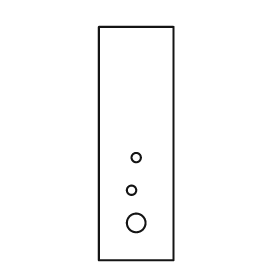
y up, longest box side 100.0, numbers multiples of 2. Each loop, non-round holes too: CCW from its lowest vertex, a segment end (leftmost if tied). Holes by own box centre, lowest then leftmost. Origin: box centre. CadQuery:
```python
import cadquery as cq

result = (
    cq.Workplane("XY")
    .moveTo(-16.0, -50.0)
    .lineTo(16.0, -50.0)
    .lineTo(16.0, 50.0)
    .lineTo(-16.0, 50.0)
    .close()
    .moveTo(0.0, -34.0)
    .circle(4.0)
    .moveTo(-2.0, -20.0)
    .circle(2.0)
    .moveTo(0.0, -6.0)
    .circle(2.0)
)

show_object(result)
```